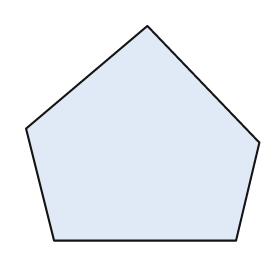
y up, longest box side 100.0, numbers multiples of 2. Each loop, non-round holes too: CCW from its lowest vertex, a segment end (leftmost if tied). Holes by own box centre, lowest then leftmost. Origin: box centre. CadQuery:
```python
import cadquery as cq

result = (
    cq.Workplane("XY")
    .moveTo(-38.0, -46.0)
    .lineTo(40.0, -46.0)
    .lineTo(50.0, -4.0)
    .lineTo(2.0, 46.0)
    .lineTo(-50.0, 2.0)
    .close()
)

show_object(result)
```